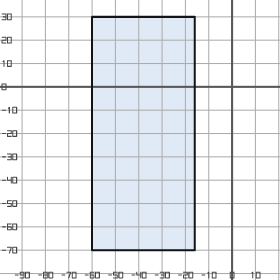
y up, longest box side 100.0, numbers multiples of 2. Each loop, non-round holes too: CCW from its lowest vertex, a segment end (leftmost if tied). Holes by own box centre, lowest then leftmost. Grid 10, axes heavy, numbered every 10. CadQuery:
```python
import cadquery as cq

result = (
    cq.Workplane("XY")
    .moveTo(-60.0, -70.0)
    .lineTo(-16.0, -70.0)
    .lineTo(-16.0, 30.0)
    .lineTo(-60.0, 30.0)
    .close()
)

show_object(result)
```